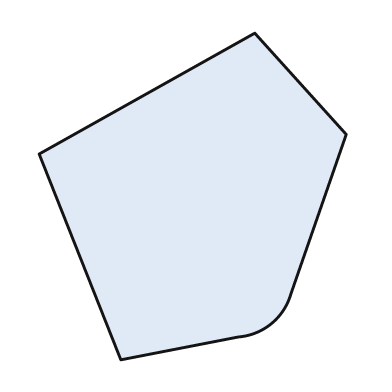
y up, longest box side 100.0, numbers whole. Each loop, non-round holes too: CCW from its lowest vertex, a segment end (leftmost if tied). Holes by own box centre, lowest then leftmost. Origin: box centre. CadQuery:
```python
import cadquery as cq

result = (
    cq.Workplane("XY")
    .moveTo(-22.0, -50.0)
    .lineTo(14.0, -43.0)
    .threePointArc((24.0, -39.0), (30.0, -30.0))
    .lineTo(47.0, 19.0)
    .lineTo(19.0, 50.0)
    .lineTo(-47.0, 13.0)
    .close()
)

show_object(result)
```